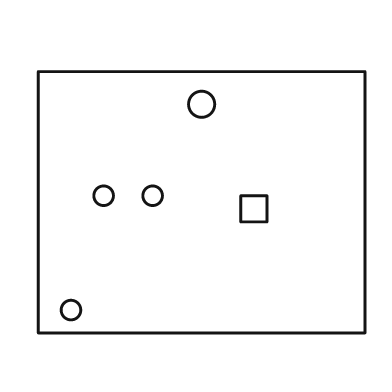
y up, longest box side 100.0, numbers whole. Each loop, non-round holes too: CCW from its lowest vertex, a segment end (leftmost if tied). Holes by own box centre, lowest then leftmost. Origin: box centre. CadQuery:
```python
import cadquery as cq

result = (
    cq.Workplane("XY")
    .moveTo(-50.0, -40.0)
    .lineTo(50.0, -40.0)
    .lineTo(50.0, 40.0)
    .lineTo(-50.0, 40.0)
    .close()
    .moveTo(-40.0, -33.0)
    .circle(3.0)
    .moveTo(12.0, -6.0)
    .lineTo(20.0, -6.0)
    .lineTo(20.0, 2.0)
    .lineTo(12.0, 2.0)
    .close()
    .moveTo(-30.0, 2.0)
    .circle(3.0)
    .moveTo(-15.0, 2.0)
    .circle(3.0)
    .moveTo(0.0, 30.0)
    .circle(4.0)
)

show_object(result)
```